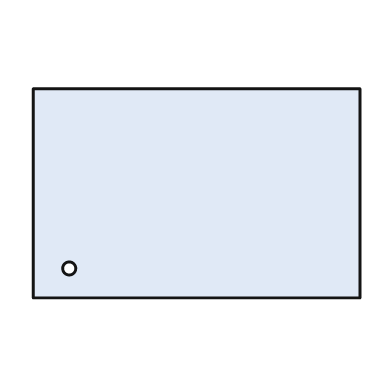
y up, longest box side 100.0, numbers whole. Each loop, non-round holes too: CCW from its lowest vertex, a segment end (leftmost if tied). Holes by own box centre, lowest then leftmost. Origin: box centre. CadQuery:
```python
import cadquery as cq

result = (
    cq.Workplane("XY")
    .moveTo(-50.0, -32.0)
    .lineTo(50.0, -32.0)
    .lineTo(50.0, 32.0)
    .lineTo(-50.0, 32.0)
    .close()
    .moveTo(-39.0, -23.0)
    .circle(2.0)
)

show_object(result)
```